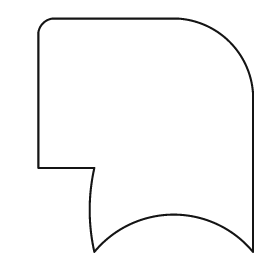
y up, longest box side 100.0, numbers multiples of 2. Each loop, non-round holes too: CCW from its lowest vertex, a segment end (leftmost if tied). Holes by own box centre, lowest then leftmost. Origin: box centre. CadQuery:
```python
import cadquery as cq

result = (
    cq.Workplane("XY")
    .moveTo(-22.0, -50.0)
    .threePointArc((12.0, -34.0), (46.0, -50.0))
    .lineTo(46.0, 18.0)
    .threePointArc((36.0, 40.0), (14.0, 50.0))
    .lineTo(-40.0, 50.0)
    .threePointArc((-44.0, 48.0), (-46.0, 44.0))
    .lineTo(-46.0, -14.0)
    .lineTo(-22.0, -14.0)
    .threePointArc((-24.0, -32.0), (-22.0, -50.0))
    .close()
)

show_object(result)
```